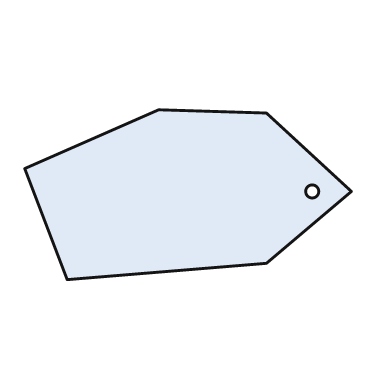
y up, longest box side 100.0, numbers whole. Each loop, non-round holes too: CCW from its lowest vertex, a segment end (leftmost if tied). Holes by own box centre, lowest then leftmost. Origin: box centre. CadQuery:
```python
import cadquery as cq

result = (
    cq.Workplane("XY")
    .moveTo(-37.0, -26.0)
    .lineTo(24.0, -21.0)
    .lineTo(50.0, 1.0)
    .lineTo(24.0, 25.0)
    .lineTo(-9.0, 26.0)
    .lineTo(-50.0, 8.0)
    .close()
    .moveTo(38.0, 1.0)
    .circle(2.0)
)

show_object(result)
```